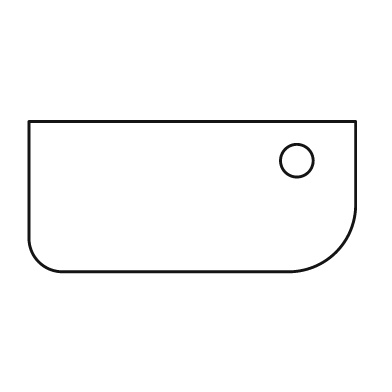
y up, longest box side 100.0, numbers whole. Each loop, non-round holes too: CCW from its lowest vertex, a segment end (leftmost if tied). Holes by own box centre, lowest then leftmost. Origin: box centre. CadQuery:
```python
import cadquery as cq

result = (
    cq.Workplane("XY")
    .moveTo(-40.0, -23.0)
    .lineTo(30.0, -23.0)
    .threePointArc((44.0, -17.0), (50.0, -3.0))
    .lineTo(50.0, 23.0)
    .lineTo(-50.0, 23.0)
    .lineTo(-50.0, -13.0)
    .threePointArc((-47.0, -20.0), (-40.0, -23.0))
    .close()
    .moveTo(32.0, 11.0)
    .circle(5.0)
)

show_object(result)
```